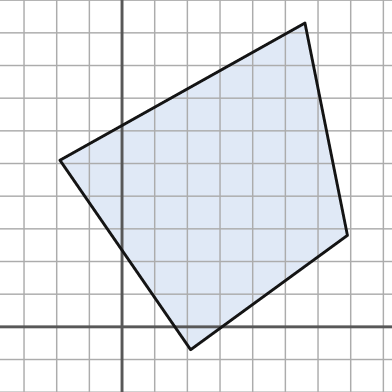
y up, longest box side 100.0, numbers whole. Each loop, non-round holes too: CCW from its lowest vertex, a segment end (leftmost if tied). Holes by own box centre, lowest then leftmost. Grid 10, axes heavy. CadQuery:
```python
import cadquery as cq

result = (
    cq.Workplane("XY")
    .moveTo(21.0, -7.0)
    .lineTo(69.0, 28.0)
    .lineTo(56.0, 93.0)
    .lineTo(-19.0, 51.0)
    .close()
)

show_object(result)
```